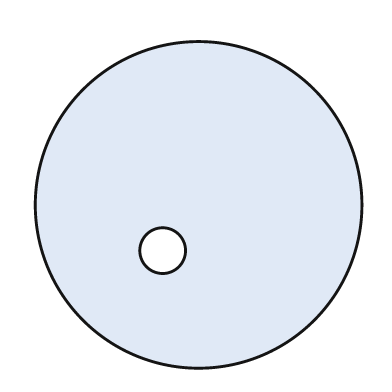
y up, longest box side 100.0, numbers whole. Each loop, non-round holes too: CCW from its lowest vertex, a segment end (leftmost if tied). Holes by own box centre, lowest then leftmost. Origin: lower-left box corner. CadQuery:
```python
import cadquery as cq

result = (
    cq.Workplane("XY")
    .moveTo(50.0, 50.0)
    .circle(50.0)
    .moveTo(39.0, 36.0)
    .circle(7.0)
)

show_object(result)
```